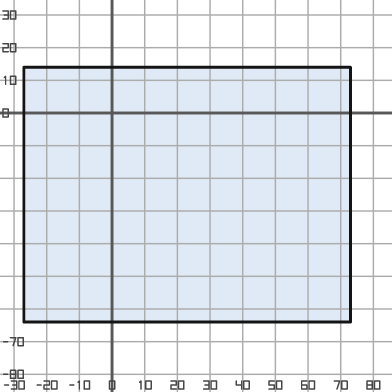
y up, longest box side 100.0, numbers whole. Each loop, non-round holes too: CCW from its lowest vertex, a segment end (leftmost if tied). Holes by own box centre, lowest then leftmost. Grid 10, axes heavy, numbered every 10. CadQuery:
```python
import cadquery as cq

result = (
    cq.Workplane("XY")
    .moveTo(-27.0, -64.0)
    .lineTo(73.0, -64.0)
    .lineTo(73.0, 14.0)
    .lineTo(-27.0, 14.0)
    .close()
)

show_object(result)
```